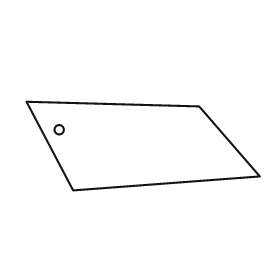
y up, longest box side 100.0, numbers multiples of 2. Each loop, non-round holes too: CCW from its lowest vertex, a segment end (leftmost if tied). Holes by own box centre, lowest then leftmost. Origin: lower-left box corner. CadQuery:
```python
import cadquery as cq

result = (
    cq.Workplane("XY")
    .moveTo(20.0, 0.0)
    .lineTo(100.0, 6.0)
    .lineTo(74.0, 36.0)
    .lineTo(0.0, 38.0)
    .close()
    .moveTo(14.0, 26.0)
    .circle(2.0)
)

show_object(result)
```